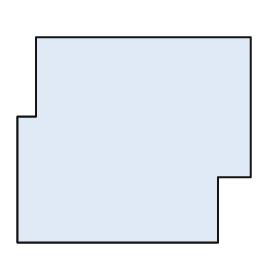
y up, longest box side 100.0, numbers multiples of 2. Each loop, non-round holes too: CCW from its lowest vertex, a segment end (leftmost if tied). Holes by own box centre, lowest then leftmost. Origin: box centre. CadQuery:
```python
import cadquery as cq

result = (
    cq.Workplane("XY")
    .moveTo(-50.0, -44.0)
    .lineTo(36.0, -44.0)
    .lineTo(36.0, -16.0)
    .lineTo(50.0, -16.0)
    .lineTo(50.0, 44.0)
    .lineTo(-42.0, 44.0)
    .lineTo(-42.0, 10.0)
    .lineTo(-50.0, 10.0)
    .close()
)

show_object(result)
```